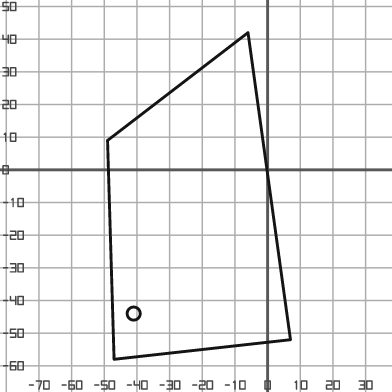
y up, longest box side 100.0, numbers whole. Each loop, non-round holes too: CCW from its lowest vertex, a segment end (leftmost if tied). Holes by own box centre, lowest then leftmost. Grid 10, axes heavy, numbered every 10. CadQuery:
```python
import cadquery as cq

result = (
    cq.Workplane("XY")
    .moveTo(-47.0, -58.0)
    .lineTo(7.0, -52.0)
    .lineTo(-6.0, 42.0)
    .lineTo(-49.0, 9.0)
    .close()
    .moveTo(-41.0, -44.0)
    .circle(2.0)
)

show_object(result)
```